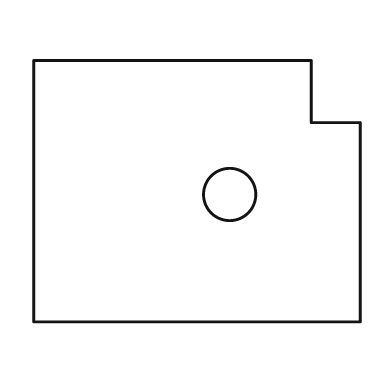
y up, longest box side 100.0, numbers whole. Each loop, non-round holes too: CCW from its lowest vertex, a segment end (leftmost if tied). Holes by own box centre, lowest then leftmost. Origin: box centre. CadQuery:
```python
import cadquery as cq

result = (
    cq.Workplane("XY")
    .moveTo(-50.0, -40.0)
    .lineTo(50.0, -40.0)
    .lineTo(50.0, 21.0)
    .lineTo(35.0, 21.0)
    .lineTo(35.0, 40.0)
    .lineTo(-50.0, 40.0)
    .close()
    .moveTo(10.0, -1.0)
    .circle(8.0)
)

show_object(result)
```